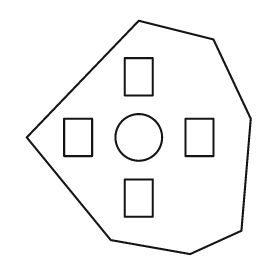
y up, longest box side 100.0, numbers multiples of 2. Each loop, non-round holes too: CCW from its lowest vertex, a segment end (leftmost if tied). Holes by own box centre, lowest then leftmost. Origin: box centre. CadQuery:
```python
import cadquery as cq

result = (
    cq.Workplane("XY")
    .moveTo(22.0, -50.0)
    .lineTo(44.0, -40.0)
    .lineTo(48.0, 8.0)
    .lineTo(32.0, 42.0)
    .lineTo(0.0, 50.0)
    .lineTo(-48.0, 0.0)
    .lineTo(-12.0, -44.0)
    .close()
    .moveTo(-6.0, -34.0)
    .lineTo(6.0, -34.0)
    .lineTo(6.0, -18.0)
    .lineTo(-6.0, -18.0)
    .close()
    .moveTo(-32.0, -8.0)
    .lineTo(-20.0, -8.0)
    .lineTo(-20.0, 8.0)
    .lineTo(-32.0, 8.0)
    .close()
    .moveTo(0.0, 0.0)
    .circle(10.0)
    .moveTo(20.0, -8.0)
    .lineTo(32.0, -8.0)
    .lineTo(32.0, 8.0)
    .lineTo(20.0, 8.0)
    .close()
    .moveTo(-6.0, 18.0)
    .lineTo(6.0, 18.0)
    .lineTo(6.0, 34.0)
    .lineTo(-6.0, 34.0)
    .close()
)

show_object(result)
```